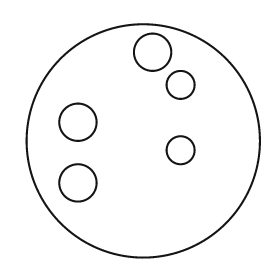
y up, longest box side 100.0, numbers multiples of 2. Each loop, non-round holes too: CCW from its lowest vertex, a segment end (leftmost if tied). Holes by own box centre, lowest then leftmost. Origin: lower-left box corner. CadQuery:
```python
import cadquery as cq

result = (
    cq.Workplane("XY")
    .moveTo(50.0, 50.0)
    .circle(50.0)
    .moveTo(22.0, 32.0)
    .circle(8.0)
    .moveTo(66.0, 46.0)
    .circle(6.0)
    .moveTo(22.0, 58.0)
    .circle(8.0)
    .moveTo(66.0, 74.0)
    .circle(6.0)
    .moveTo(54.0, 88.0)
    .circle(8.0)
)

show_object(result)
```